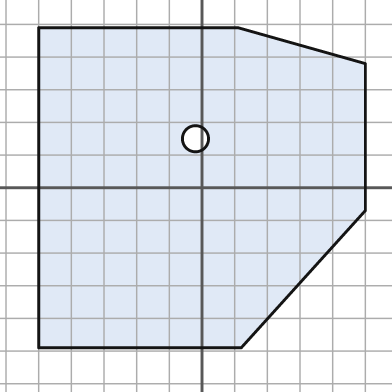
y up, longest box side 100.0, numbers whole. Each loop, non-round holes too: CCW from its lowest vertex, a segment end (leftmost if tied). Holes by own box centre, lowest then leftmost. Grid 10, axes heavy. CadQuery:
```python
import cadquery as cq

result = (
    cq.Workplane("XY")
    .moveTo(-50.0, -49.0)
    .lineTo(12.0, -49.0)
    .lineTo(50.0, -7.0)
    .lineTo(50.0, 38.0)
    .lineTo(11.0, 49.0)
    .lineTo(-50.0, 49.0)
    .close()
    .moveTo(-2.0, 15.0)
    .circle(4.0)
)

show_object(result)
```